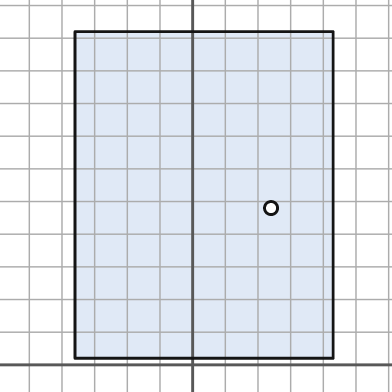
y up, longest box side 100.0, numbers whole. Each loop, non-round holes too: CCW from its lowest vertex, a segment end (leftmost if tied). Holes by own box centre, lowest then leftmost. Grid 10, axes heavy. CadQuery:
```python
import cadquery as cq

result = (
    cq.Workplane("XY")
    .moveTo(-36.0, 2.0)
    .lineTo(43.0, 2.0)
    .lineTo(43.0, 102.0)
    .lineTo(-36.0, 102.0)
    .close()
    .moveTo(24.0, 48.0)
    .circle(2.0)
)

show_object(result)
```